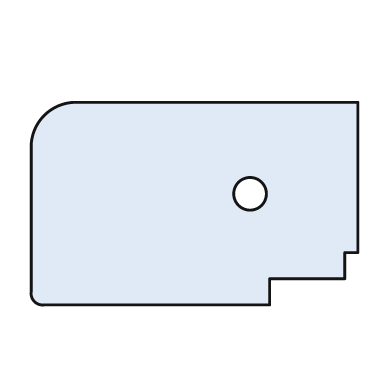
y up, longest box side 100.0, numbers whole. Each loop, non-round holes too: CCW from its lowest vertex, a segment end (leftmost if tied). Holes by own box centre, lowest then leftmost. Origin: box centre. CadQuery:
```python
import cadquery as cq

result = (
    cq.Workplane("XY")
    .moveTo(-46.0, -31.0)
    .lineTo(23.0, -31.0)
    .lineTo(23.0, -23.0)
    .lineTo(46.0, -23.0)
    .lineTo(46.0, -15.0)
    .lineTo(50.0, -15.0)
    .lineTo(50.0, 31.0)
    .lineTo(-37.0, 31.0)
    .threePointArc((-46.0, 27.0), (-50.0, 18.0))
    .lineTo(-50.0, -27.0)
    .threePointArc((-49.0, -30.0), (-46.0, -31.0))
    .close()
    .moveTo(17.0, 3.0)
    .circle(5.0)
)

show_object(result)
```